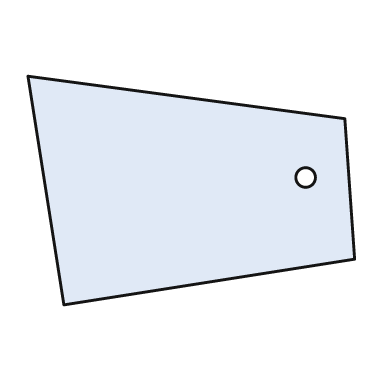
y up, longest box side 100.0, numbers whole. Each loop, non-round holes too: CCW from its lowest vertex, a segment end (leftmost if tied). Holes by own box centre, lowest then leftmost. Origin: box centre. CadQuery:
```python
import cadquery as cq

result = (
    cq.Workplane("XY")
    .moveTo(-39.0, -35.0)
    .lineTo(50.0, -21.0)
    .lineTo(47.0, 22.0)
    .lineTo(-50.0, 35.0)
    .close()
    .moveTo(35.0, 4.0)
    .circle(3.0)
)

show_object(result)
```